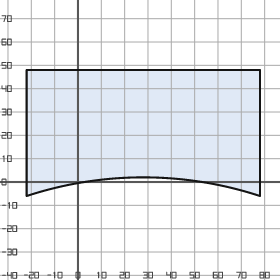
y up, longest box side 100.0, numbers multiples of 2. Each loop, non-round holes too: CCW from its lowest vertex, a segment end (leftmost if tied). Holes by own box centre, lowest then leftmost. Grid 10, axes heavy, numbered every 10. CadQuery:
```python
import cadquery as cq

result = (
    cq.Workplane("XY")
    .moveTo(-22.0, -6.0)
    .threePointArc((28.0, 2.0), (78.0, -6.0))
    .lineTo(78.0, 48.0)
    .lineTo(-22.0, 48.0)
    .close()
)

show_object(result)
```